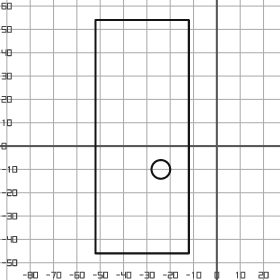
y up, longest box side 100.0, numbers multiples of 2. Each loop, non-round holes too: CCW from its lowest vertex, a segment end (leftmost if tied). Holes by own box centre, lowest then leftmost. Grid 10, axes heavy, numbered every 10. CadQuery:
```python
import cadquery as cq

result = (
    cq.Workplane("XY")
    .moveTo(-52.0, -46.0)
    .lineTo(-12.0, -46.0)
    .lineTo(-12.0, 54.0)
    .lineTo(-52.0, 54.0)
    .close()
    .moveTo(-24.0, -10.0)
    .circle(4.0)
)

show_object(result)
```